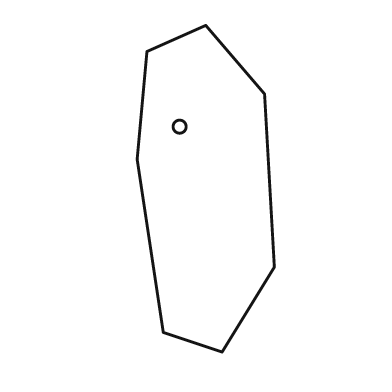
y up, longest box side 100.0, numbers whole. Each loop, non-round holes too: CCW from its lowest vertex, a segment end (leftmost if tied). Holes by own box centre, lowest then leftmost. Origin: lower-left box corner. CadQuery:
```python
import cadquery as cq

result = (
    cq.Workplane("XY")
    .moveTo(26.0, 0.0)
    .lineTo(42.0, 26.0)
    .lineTo(39.0, 79.0)
    .lineTo(21.0, 100.0)
    .lineTo(3.0, 92.0)
    .lineTo(0.0, 59.0)
    .lineTo(8.0, 6.0)
    .close()
    .moveTo(13.0, 69.0)
    .circle(2.0)
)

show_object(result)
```